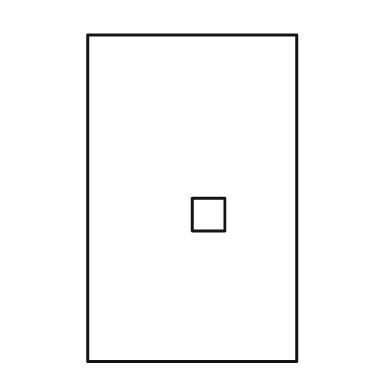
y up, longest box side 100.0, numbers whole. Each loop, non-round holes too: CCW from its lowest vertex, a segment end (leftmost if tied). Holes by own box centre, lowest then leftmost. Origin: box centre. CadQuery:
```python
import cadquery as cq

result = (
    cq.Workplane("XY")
    .moveTo(-32.0, -50.0)
    .lineTo(32.0, -50.0)
    .lineTo(32.0, 50.0)
    .lineTo(-32.0, 50.0)
    .close()
    .moveTo(0.0, -10.0)
    .lineTo(10.0, -10.0)
    .lineTo(10.0, 0.0)
    .lineTo(0.0, 0.0)
    .close()
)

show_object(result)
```